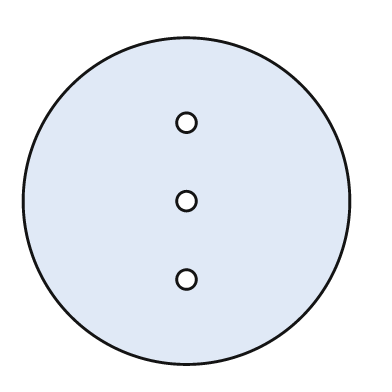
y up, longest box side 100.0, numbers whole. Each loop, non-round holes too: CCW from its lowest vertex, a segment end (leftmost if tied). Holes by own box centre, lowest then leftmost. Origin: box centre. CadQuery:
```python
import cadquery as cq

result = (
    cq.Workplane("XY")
    .moveTo(0.0, 0.0)
    .circle(50.0)
    .moveTo(0.0, -24.0)
    .circle(3.0)
    .moveTo(0.0, 0.0)
    .circle(3.0)
    .moveTo(0.0, 24.0)
    .circle(3.0)
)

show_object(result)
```